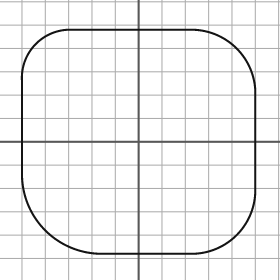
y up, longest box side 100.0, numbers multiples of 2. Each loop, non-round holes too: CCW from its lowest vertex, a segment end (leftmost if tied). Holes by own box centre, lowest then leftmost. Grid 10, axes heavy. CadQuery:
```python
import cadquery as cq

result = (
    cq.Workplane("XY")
    .moveTo(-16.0, -48.0)
    .lineTo(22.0, -48.0)
    .threePointArc((42.0, -40.0), (50.0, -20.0))
    .lineTo(50.0, 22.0)
    .threePointArc((42.0, 40.0), (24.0, 48.0))
    .lineTo(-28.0, 48.0)
    .threePointArc((-44.0, 42.0), (-50.0, 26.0))
    .lineTo(-50.0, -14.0)
    .threePointArc((-40.0, -38.0), (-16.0, -48.0))
    .close()
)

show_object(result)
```